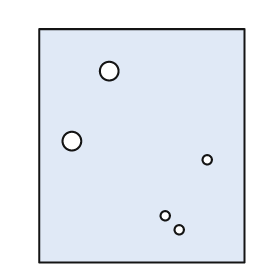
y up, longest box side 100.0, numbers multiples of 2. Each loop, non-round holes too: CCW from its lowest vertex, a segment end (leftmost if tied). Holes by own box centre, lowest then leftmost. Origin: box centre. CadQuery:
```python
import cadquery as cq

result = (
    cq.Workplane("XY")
    .moveTo(-44.0, -50.0)
    .lineTo(44.0, -50.0)
    .lineTo(44.0, 50.0)
    .lineTo(-44.0, 50.0)
    .close()
    .moveTo(16.0, -36.0)
    .circle(2.0)
    .moveTo(10.0, -30.0)
    .circle(2.0)
    .moveTo(28.0, -6.0)
    .circle(2.0)
    .moveTo(-30.0, 2.0)
    .circle(4.0)
    .moveTo(-14.0, 32.0)
    .circle(4.0)
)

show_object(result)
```